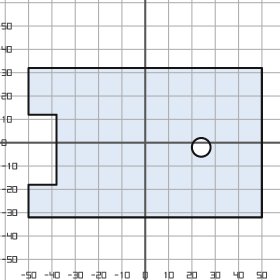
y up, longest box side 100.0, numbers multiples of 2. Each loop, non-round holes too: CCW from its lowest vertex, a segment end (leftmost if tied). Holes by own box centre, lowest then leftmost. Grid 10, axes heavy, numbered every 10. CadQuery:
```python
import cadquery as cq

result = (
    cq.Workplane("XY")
    .moveTo(-50.0, -32.0)
    .lineTo(50.0, -32.0)
    .lineTo(50.0, 32.0)
    .lineTo(-50.0, 32.0)
    .lineTo(-50.0, 12.0)
    .lineTo(-38.0, 12.0)
    .lineTo(-38.0, -18.0)
    .lineTo(-50.0, -18.0)
    .close()
    .moveTo(24.0, -2.0)
    .circle(4.0)
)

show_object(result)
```